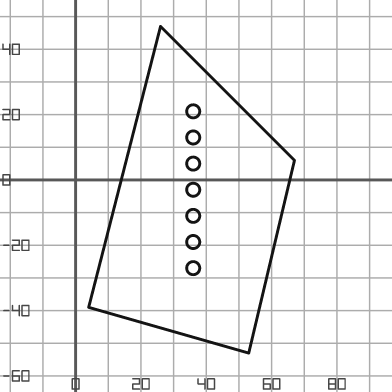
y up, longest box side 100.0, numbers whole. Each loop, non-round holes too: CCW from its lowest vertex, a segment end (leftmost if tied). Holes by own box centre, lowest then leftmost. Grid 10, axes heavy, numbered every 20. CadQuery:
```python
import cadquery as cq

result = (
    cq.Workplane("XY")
    .moveTo(53.0, -53.0)
    .lineTo(67.0, 6.0)
    .lineTo(26.0, 47.0)
    .lineTo(4.0, -39.0)
    .close()
    .moveTo(36.0, -27.0)
    .circle(2.0)
    .moveTo(36.0, -19.0)
    .circle(2.0)
    .moveTo(36.0, -11.0)
    .circle(2.0)
    .moveTo(36.0, -3.0)
    .circle(2.0)
    .moveTo(36.0, 5.0)
    .circle(2.0)
    .moveTo(36.0, 13.0)
    .circle(2.0)
    .moveTo(36.0, 21.0)
    .circle(2.0)
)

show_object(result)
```